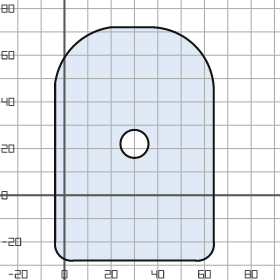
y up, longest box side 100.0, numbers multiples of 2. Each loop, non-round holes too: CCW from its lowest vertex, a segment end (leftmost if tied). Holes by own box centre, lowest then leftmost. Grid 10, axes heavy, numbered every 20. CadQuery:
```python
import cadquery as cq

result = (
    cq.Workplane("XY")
    .moveTo(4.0, -28.0)
    .lineTo(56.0, -28.0)
    .threePointArc((62.0, -26.0), (64.0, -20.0))
    .lineTo(64.0, 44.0)
    .threePointArc((56.0, 64.0), (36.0, 72.0))
    .lineTo(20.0, 72.0)
    .threePointArc((4.0, 64.0), (-4.0, 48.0))
    .lineTo(-4.0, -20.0)
    .threePointArc((-2.0, -26.0), (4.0, -28.0))
    .close()
    .moveTo(30.0, 22.0)
    .circle(6.0)
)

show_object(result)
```